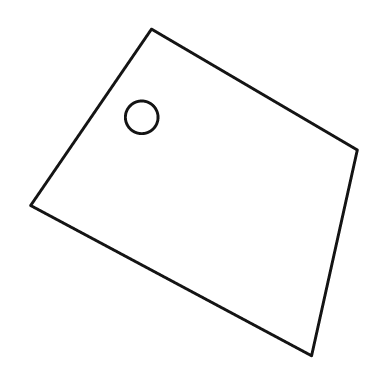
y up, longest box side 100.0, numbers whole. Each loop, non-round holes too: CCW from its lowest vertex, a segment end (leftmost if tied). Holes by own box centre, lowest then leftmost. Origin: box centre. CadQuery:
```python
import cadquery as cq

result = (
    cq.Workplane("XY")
    .moveTo(36.0, -50.0)
    .lineTo(50.0, 13.0)
    .lineTo(-13.0, 50.0)
    .lineTo(-50.0, -4.0)
    .close()
    .moveTo(-16.0, 23.0)
    .circle(5.0)
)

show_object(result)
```